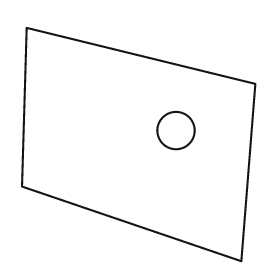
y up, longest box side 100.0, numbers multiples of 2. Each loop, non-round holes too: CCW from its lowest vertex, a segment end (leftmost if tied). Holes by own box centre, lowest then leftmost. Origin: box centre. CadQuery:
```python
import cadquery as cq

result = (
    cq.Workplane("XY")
    .moveTo(44.0, -50.0)
    .lineTo(50.0, 26.0)
    .lineTo(-48.0, 50.0)
    .lineTo(-50.0, -18.0)
    .close()
    .moveTo(16.0, 6.0)
    .circle(8.0)
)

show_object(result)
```